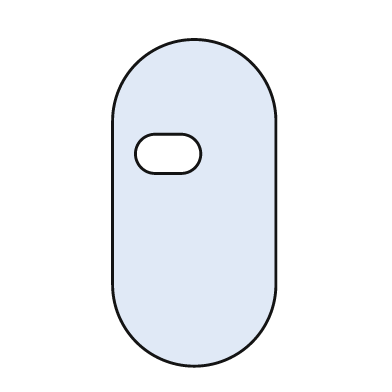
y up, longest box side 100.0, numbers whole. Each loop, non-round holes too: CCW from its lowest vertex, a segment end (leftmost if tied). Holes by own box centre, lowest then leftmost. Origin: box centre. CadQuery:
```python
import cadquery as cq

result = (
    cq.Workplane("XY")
    .moveTo(-25.0, -25.0)
    .threePointArc((0.0, -50.0), (25.0, -25.0))
    .lineTo(25.0, 25.0)
    .threePointArc((0.0, 50.0), (-25.0, 25.0))
    .close()
    .moveTo(-12.0, 9.0)
    .lineTo(-4.0, 9.0)
    .threePointArc((2.0, 15.0), (-4.0, 21.0))
    .lineTo(-12.0, 21.0)
    .threePointArc((-18.0, 15.0), (-12.0, 9.0))
    .close()
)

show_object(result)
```